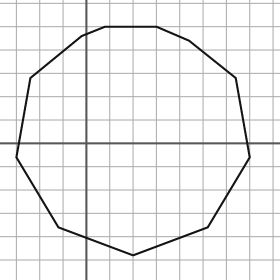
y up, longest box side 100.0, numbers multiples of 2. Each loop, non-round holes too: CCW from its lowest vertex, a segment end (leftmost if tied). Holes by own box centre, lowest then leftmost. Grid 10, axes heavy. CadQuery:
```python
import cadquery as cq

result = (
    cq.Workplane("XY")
    .moveTo(20.0, -48.0)
    .lineTo(52.0, -36.0)
    .lineTo(70.0, -6.0)
    .lineTo(64.0, 28.0)
    .lineTo(44.0, 44.0)
    .lineTo(30.0, 50.0)
    .lineTo(8.0, 50.0)
    .lineTo(-2.0, 46.0)
    .lineTo(-24.0, 28.0)
    .lineTo(-30.0, -6.0)
    .lineTo(-12.0, -36.0)
    .close()
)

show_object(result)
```